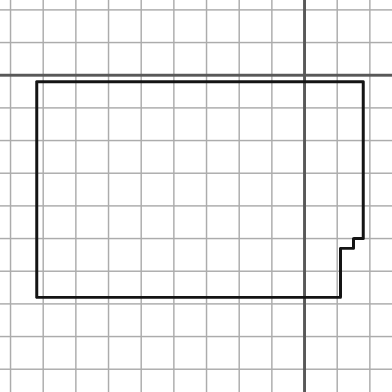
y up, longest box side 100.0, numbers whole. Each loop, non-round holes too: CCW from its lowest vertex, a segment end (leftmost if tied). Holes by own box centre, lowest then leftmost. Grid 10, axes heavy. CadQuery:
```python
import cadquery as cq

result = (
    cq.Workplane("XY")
    .moveTo(-82.0, -68.0)
    .lineTo(11.0, -68.0)
    .lineTo(11.0, -53.0)
    .lineTo(15.0, -53.0)
    .lineTo(15.0, -50.0)
    .lineTo(18.0, -50.0)
    .lineTo(18.0, -2.0)
    .lineTo(-82.0, -2.0)
    .close()
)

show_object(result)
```